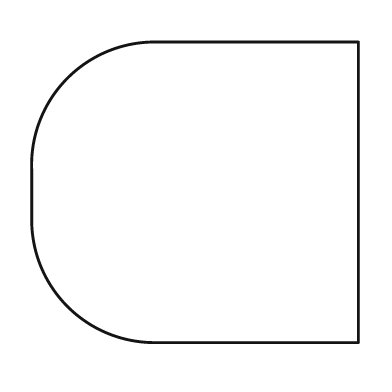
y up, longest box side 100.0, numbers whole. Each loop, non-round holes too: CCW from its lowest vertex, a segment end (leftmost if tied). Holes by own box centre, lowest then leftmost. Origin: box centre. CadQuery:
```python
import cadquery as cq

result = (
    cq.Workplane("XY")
    .moveTo(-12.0, -46.0)
    .lineTo(50.0, -46.0)
    .lineTo(50.0, 46.0)
    .lineTo(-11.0, 46.0)
    .threePointArc((-39.0, 35.0), (-50.0, 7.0))
    .lineTo(-50.0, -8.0)
    .threePointArc((-39.0, -35.0), (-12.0, -46.0))
    .close()
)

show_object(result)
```